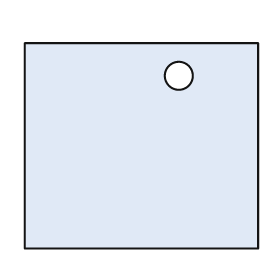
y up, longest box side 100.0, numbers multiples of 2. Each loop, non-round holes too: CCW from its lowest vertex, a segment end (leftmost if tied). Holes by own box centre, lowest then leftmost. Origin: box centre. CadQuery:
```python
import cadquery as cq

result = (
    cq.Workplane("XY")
    .moveTo(-50.0, -44.0)
    .lineTo(50.0, -44.0)
    .lineTo(50.0, 44.0)
    .lineTo(-50.0, 44.0)
    .close()
    .moveTo(16.0, 30.0)
    .circle(6.0)
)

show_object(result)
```